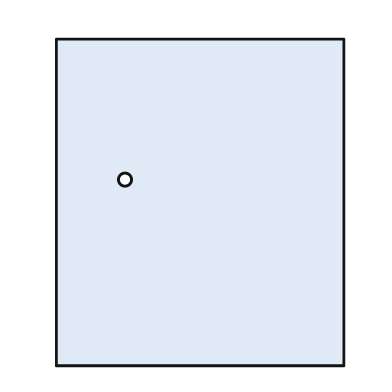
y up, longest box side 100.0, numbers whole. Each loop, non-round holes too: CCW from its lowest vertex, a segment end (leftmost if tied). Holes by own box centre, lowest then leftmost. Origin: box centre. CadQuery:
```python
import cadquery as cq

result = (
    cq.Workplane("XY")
    .moveTo(-44.0, -50.0)
    .lineTo(44.0, -50.0)
    .lineTo(44.0, 50.0)
    .lineTo(-44.0, 50.0)
    .close()
    .moveTo(-23.0, 7.0)
    .circle(2.0)
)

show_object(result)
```